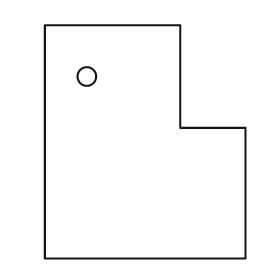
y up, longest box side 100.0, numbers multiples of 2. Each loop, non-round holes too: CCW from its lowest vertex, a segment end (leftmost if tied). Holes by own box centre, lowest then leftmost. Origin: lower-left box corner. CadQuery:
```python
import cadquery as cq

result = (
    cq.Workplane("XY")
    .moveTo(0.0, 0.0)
    .lineTo(86.0, 0.0)
    .lineTo(86.0, 56.0)
    .lineTo(58.0, 56.0)
    .lineTo(58.0, 100.0)
    .lineTo(0.0, 100.0)
    .close()
    .moveTo(18.0, 78.0)
    .circle(4.0)
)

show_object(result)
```